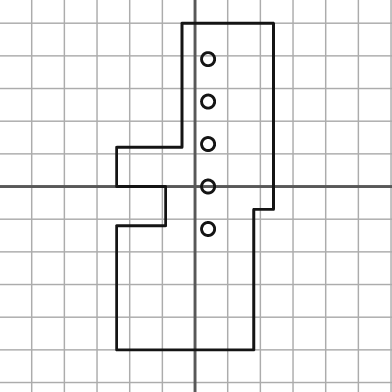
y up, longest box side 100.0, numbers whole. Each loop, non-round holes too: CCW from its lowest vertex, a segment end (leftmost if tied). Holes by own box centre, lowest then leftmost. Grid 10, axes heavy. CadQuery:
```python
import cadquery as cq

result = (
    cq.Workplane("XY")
    .moveTo(-24.0, -50.0)
    .lineTo(18.0, -50.0)
    .lineTo(18.0, -7.0)
    .lineTo(24.0, -7.0)
    .lineTo(24.0, 50.0)
    .lineTo(-4.0, 50.0)
    .lineTo(-4.0, 12.0)
    .lineTo(-24.0, 12.0)
    .lineTo(-24.0, 0.0)
    .lineTo(-9.0, 0.0)
    .lineTo(-9.0, -12.0)
    .lineTo(-24.0, -12.0)
    .close()
    .moveTo(4.0, -13.0)
    .circle(2.0)
    .moveTo(4.0, 0.0)
    .circle(2.0)
    .moveTo(4.0, 13.0)
    .circle(2.0)
    .moveTo(4.0, 26.0)
    .circle(2.0)
    .moveTo(4.0, 39.0)
    .circle(2.0)
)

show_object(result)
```